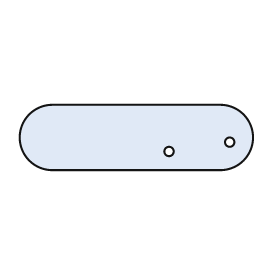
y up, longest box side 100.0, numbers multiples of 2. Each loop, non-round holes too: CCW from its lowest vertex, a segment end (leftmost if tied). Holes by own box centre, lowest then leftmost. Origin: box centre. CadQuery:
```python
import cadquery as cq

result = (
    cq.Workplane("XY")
    .moveTo(-36.0, -14.0)
    .lineTo(36.0, -14.0)
    .threePointArc((50.0, 0.0), (36.0, 14.0))
    .lineTo(-36.0, 14.0)
    .threePointArc((-50.0, 0.0), (-36.0, -14.0))
    .close()
    .moveTo(14.0, -6.0)
    .circle(2.0)
    .moveTo(40.0, -2.0)
    .circle(2.0)
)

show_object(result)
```